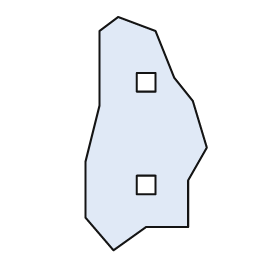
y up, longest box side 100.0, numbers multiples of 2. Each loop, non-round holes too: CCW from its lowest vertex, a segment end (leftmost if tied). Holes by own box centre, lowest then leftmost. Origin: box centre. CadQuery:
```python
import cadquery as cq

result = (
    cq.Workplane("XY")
    .moveTo(-14.0, -50.0)
    .lineTo(0.0, -40.0)
    .lineTo(18.0, -40.0)
    .lineTo(18.0, -20.0)
    .lineTo(26.0, -6.0)
    .lineTo(20.0, 14.0)
    .lineTo(12.0, 24.0)
    .lineTo(4.0, 44.0)
    .lineTo(-12.0, 50.0)
    .lineTo(-20.0, 44.0)
    .lineTo(-20.0, 12.0)
    .lineTo(-26.0, -12.0)
    .lineTo(-26.0, -36.0)
    .close()
    .moveTo(-4.0, -26.0)
    .lineTo(4.0, -26.0)
    .lineTo(4.0, -18.0)
    .lineTo(-4.0, -18.0)
    .close()
    .moveTo(-4.0, 18.0)
    .lineTo(4.0, 18.0)
    .lineTo(4.0, 26.0)
    .lineTo(-4.0, 26.0)
    .close()
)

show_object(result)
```